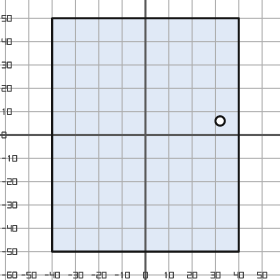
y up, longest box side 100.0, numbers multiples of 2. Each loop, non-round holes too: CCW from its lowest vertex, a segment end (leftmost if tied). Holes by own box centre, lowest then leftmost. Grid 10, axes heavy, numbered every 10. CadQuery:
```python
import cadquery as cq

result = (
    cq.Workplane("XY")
    .moveTo(-40.0, -50.0)
    .lineTo(40.0, -50.0)
    .lineTo(40.0, 50.0)
    .lineTo(-40.0, 50.0)
    .close()
    .moveTo(32.0, 6.0)
    .circle(2.0)
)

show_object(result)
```